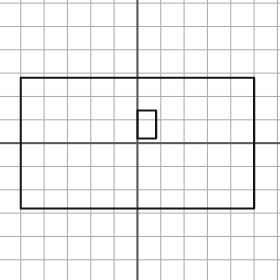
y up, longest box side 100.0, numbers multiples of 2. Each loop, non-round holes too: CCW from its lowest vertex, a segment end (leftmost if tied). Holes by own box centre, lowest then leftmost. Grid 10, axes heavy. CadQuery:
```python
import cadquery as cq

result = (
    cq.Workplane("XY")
    .moveTo(-50.0, -28.0)
    .lineTo(50.0, -28.0)
    .lineTo(50.0, 28.0)
    .lineTo(-50.0, 28.0)
    .close()
    .moveTo(0.0, 2.0)
    .lineTo(8.0, 2.0)
    .lineTo(8.0, 14.0)
    .lineTo(0.0, 14.0)
    .close()
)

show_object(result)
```